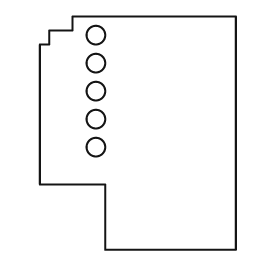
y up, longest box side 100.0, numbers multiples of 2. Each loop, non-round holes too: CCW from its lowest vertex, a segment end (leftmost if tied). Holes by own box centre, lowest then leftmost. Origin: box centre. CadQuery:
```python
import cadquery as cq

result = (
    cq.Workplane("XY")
    .moveTo(-14.0, -50.0)
    .lineTo(42.0, -50.0)
    .lineTo(42.0, 50.0)
    .lineTo(-28.0, 50.0)
    .lineTo(-28.0, 44.0)
    .lineTo(-38.0, 44.0)
    .lineTo(-38.0, 38.0)
    .lineTo(-42.0, 38.0)
    .lineTo(-42.0, -22.0)
    .lineTo(-14.0, -22.0)
    .close()
    .moveTo(-18.0, -6.0)
    .circle(4.0)
    .moveTo(-18.0, 6.0)
    .circle(4.0)
    .moveTo(-18.0, 18.0)
    .circle(4.0)
    .moveTo(-18.0, 30.0)
    .circle(4.0)
    .moveTo(-18.0, 42.0)
    .circle(4.0)
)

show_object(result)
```